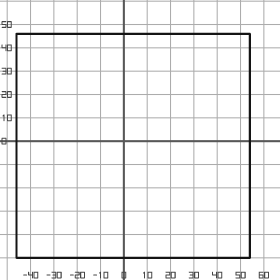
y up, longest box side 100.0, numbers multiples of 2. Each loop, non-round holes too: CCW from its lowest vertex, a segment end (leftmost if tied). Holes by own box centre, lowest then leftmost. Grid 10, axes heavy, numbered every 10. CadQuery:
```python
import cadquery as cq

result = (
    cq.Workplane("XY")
    .moveTo(-46.0, -50.0)
    .lineTo(54.0, -50.0)
    .lineTo(54.0, 46.0)
    .lineTo(-46.0, 46.0)
    .close()
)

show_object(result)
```